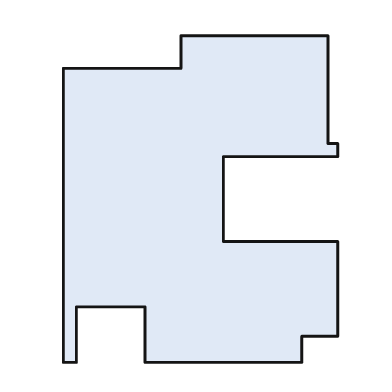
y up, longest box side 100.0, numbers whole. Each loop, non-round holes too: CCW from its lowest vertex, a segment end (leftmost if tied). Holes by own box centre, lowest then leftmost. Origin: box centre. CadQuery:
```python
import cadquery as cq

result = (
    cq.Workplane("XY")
    .moveTo(-42.0, -50.0)
    .lineTo(-38.0, -50.0)
    .lineTo(-38.0, -33.0)
    .lineTo(-17.0, -33.0)
    .lineTo(-17.0, -50.0)
    .lineTo(31.0, -50.0)
    .lineTo(31.0, -42.0)
    .lineTo(42.0, -42.0)
    .lineTo(42.0, -13.0)
    .lineTo(7.0, -13.0)
    .lineTo(7.0, 13.0)
    .lineTo(42.0, 13.0)
    .lineTo(42.0, 17.0)
    .lineTo(39.0, 17.0)
    .lineTo(39.0, 50.0)
    .lineTo(-6.0, 50.0)
    .lineTo(-6.0, 40.0)
    .lineTo(-42.0, 40.0)
    .close()
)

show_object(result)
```